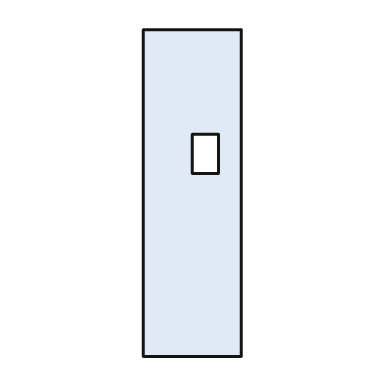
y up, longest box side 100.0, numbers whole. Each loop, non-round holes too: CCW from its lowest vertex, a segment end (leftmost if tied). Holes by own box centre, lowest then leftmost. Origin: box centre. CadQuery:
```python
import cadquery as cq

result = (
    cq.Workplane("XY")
    .moveTo(-15.0, -50.0)
    .lineTo(15.0, -50.0)
    .lineTo(15.0, 50.0)
    .lineTo(-15.0, 50.0)
    .close()
    .moveTo(0.0, 6.0)
    .lineTo(8.0, 6.0)
    .lineTo(8.0, 18.0)
    .lineTo(0.0, 18.0)
    .close()
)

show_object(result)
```